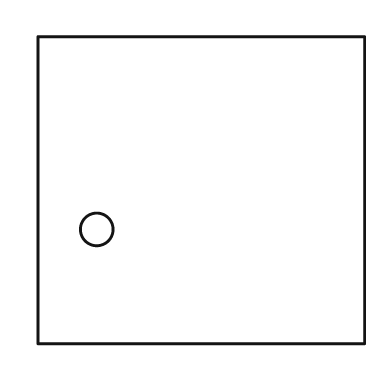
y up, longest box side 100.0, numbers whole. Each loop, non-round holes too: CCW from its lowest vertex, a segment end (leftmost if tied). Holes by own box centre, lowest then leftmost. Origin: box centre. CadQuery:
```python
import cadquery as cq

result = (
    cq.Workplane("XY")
    .moveTo(-50.0, -47.0)
    .lineTo(50.0, -47.0)
    .lineTo(50.0, 47.0)
    .lineTo(-50.0, 47.0)
    .close()
    .moveTo(-32.0, -12.0)
    .circle(5.0)
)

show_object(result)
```